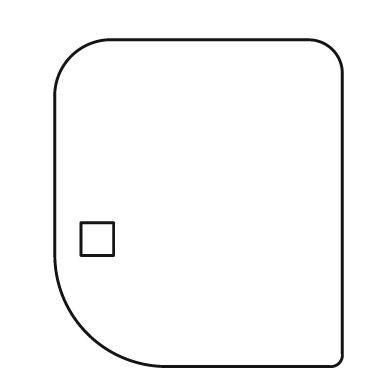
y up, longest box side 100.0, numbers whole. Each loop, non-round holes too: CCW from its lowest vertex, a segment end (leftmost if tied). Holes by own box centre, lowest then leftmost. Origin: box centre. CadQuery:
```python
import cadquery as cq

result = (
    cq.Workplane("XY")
    .moveTo(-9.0, -50.0)
    .lineTo(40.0, -50.0)
    .threePointArc((43.0, -49.0), (44.0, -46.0))
    .lineTo(44.0, 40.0)
    .threePointArc((41.0, 47.0), (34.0, 50.0))
    .lineTo(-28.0, 50.0)
    .threePointArc((-39.0, 45.0), (-44.0, 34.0))
    .lineTo(-44.0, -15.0)
    .threePointArc((-34.0, -40.0), (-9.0, -50.0))
    .close()
    .moveTo(-36.0, -16.0)
    .lineTo(-26.0, -16.0)
    .lineTo(-26.0, -6.0)
    .lineTo(-36.0, -6.0)
    .close()
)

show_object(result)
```